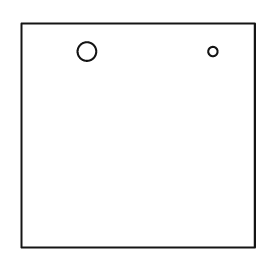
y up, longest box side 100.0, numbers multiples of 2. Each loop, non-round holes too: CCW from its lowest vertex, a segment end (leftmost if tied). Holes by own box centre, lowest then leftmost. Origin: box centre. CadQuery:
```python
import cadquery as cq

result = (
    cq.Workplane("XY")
    .moveTo(-50.0, -48.0)
    .lineTo(50.0, -48.0)
    .lineTo(50.0, 48.0)
    .lineTo(-50.0, 48.0)
    .close()
    .moveTo(-22.0, 36.0)
    .circle(4.0)
    .moveTo(32.0, 36.0)
    .circle(2.0)
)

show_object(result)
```